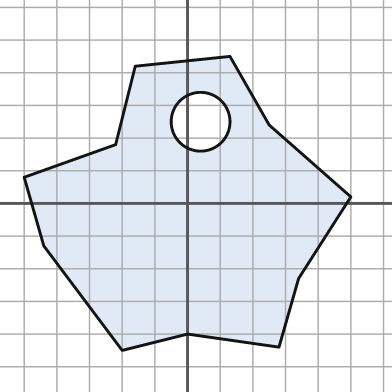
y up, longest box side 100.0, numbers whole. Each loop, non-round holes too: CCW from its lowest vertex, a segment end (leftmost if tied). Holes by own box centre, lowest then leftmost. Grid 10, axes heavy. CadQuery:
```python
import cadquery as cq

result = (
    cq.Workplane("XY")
    .moveTo(-20.0, -45.0)
    .lineTo(0.0, -40.0)
    .lineTo(28.0, -44.0)
    .lineTo(34.0, -23.0)
    .lineTo(50.0, 2.0)
    .lineTo(25.0, 24.0)
    .lineTo(13.0, 45.0)
    .lineTo(-16.0, 42.0)
    .lineTo(-22.0, 18.0)
    .lineTo(-50.0, 8.0)
    .lineTo(-44.0, -13.0)
    .close()
    .moveTo(4.0, 25.0)
    .circle(9.0)
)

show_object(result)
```